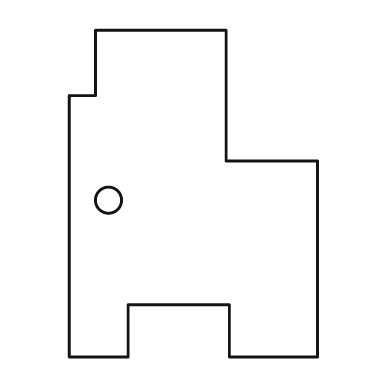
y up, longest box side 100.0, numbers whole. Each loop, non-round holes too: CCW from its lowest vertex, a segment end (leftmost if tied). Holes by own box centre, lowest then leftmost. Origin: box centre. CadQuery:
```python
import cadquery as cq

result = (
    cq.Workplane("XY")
    .moveTo(-38.0, -50.0)
    .lineTo(-20.0, -50.0)
    .lineTo(-20.0, -34.0)
    .lineTo(11.0, -34.0)
    .lineTo(11.0, -50.0)
    .lineTo(38.0, -50.0)
    .lineTo(38.0, 10.0)
    .lineTo(10.0, 10.0)
    .lineTo(10.0, 50.0)
    .lineTo(-30.0, 50.0)
    .lineTo(-30.0, 30.0)
    .lineTo(-38.0, 30.0)
    .close()
    .moveTo(-26.0, -2.0)
    .circle(4.0)
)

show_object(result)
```